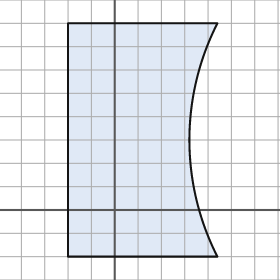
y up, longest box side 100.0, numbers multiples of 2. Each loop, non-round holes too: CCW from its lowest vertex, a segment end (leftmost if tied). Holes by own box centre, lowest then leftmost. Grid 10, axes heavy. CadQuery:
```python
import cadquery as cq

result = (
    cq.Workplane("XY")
    .moveTo(-20.0, -20.0)
    .lineTo(44.0, -20.0)
    .threePointArc((32.0, 30.0), (44.0, 80.0))
    .lineTo(-20.0, 80.0)
    .close()
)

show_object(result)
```